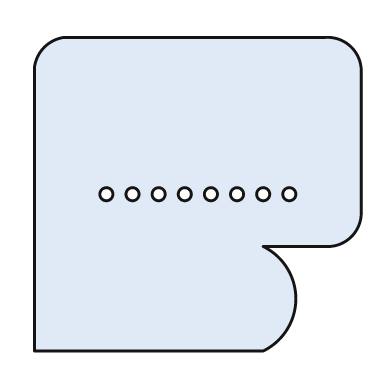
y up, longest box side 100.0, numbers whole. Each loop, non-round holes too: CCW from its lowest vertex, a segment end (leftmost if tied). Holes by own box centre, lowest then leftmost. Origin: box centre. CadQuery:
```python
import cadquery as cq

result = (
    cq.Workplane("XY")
    .moveTo(-50.0, -48.0)
    .lineTo(20.0, -48.0)
    .threePointArc((30.0, -32.0), (20.0, -16.0))
    .lineTo(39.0, -16.0)
    .threePointArc((47.0, -13.0), (50.0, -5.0))
    .lineTo(50.0, 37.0)
    .threePointArc((47.0, 45.0), (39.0, 48.0))
    .lineTo(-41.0, 48.0)
    .threePointArc((-47.0, 45.0), (-50.0, 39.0))
    .close()
    .moveTo(-28.0, 0.0)
    .circle(2.0)
    .moveTo(-20.0, 0.0)
    .circle(2.0)
    .moveTo(-12.0, 0.0)
    .circle(2.0)
    .moveTo(-4.0, 0.0)
    .circle(2.0)
    .moveTo(4.0, 0.0)
    .circle(2.0)
    .moveTo(12.0, 0.0)
    .circle(2.0)
    .moveTo(20.0, 0.0)
    .circle(2.0)
    .moveTo(28.0, 0.0)
    .circle(2.0)
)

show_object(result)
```